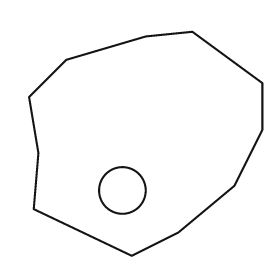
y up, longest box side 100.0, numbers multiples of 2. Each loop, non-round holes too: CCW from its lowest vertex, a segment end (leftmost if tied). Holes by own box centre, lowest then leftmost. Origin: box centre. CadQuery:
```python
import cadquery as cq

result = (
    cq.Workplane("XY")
    .moveTo(-6.0, -48.0)
    .lineTo(14.0, -38.0)
    .lineTo(38.0, -18.0)
    .lineTo(50.0, 6.0)
    .lineTo(50.0, 26.0)
    .lineTo(20.0, 48.0)
    .lineTo(0.0, 46.0)
    .lineTo(-34.0, 36.0)
    .lineTo(-50.0, 20.0)
    .lineTo(-46.0, -4.0)
    .lineTo(-48.0, -28.0)
    .close()
    .moveTo(-10.0, -20.0)
    .circle(10.0)
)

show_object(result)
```